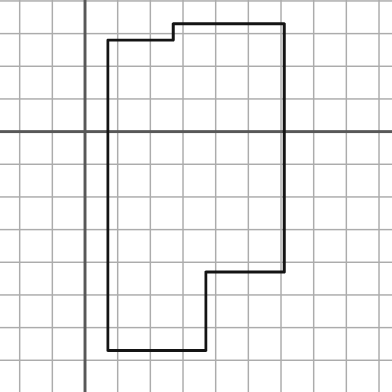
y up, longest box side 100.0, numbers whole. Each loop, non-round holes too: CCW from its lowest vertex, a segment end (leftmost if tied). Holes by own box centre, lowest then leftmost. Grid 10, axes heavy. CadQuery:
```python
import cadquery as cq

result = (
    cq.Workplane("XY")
    .moveTo(7.0, -67.0)
    .lineTo(37.0, -67.0)
    .lineTo(37.0, -43.0)
    .lineTo(61.0, -43.0)
    .lineTo(61.0, 33.0)
    .lineTo(27.0, 33.0)
    .lineTo(27.0, 28.0)
    .lineTo(7.0, 28.0)
    .close()
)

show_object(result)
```